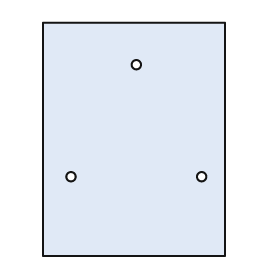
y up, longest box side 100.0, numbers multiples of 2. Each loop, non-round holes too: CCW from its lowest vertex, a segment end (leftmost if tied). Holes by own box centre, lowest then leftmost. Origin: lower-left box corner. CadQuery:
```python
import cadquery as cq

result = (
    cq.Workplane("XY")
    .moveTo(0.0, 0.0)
    .lineTo(78.0, 0.0)
    .lineTo(78.0, 100.0)
    .lineTo(0.0, 100.0)
    .close()
    .moveTo(12.0, 34.0)
    .circle(2.0)
    .moveTo(68.0, 34.0)
    .circle(2.0)
    .moveTo(40.0, 82.0)
    .circle(2.0)
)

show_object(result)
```